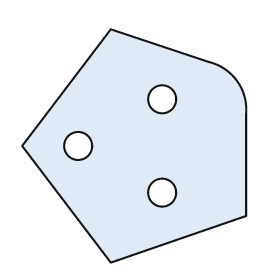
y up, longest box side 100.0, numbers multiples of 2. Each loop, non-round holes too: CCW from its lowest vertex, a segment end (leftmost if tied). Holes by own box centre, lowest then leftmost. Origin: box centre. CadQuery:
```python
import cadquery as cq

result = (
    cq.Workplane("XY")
    .moveTo(-10.0, -50.0)
    .lineTo(48.0, -30.0)
    .lineTo(48.0, 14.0)
    .threePointArc((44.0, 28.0), (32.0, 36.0))
    .lineTo(-10.0, 50.0)
    .lineTo(-48.0, 0.0)
    .close()
    .moveTo(12.0, -20.0)
    .circle(6.0)
    .moveTo(-24.0, 0.0)
    .circle(6.0)
    .moveTo(12.0, 20.0)
    .circle(6.0)
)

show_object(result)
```